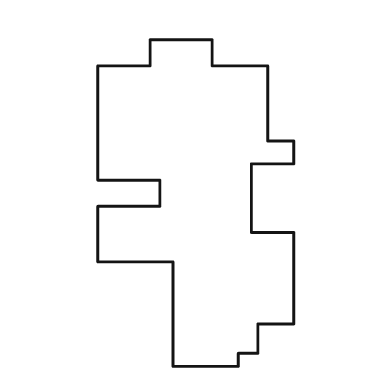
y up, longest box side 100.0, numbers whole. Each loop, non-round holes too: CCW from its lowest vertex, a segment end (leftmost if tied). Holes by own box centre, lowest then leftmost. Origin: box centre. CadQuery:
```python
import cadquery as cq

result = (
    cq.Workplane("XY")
    .moveTo(-7.0, -50.0)
    .lineTo(13.0, -50.0)
    .lineTo(13.0, -46.0)
    .lineTo(19.0, -46.0)
    .lineTo(19.0, -37.0)
    .lineTo(30.0, -37.0)
    .lineTo(30.0, -9.0)
    .lineTo(17.0, -9.0)
    .lineTo(17.0, 12.0)
    .lineTo(30.0, 12.0)
    .lineTo(30.0, 19.0)
    .lineTo(22.0, 19.0)
    .lineTo(22.0, 42.0)
    .lineTo(5.0, 42.0)
    .lineTo(5.0, 50.0)
    .lineTo(-14.0, 50.0)
    .lineTo(-14.0, 42.0)
    .lineTo(-30.0, 42.0)
    .lineTo(-30.0, 7.0)
    .lineTo(-11.0, 7.0)
    .lineTo(-11.0, -1.0)
    .lineTo(-30.0, -1.0)
    .lineTo(-30.0, -18.0)
    .lineTo(-7.0, -18.0)
    .close()
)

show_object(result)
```